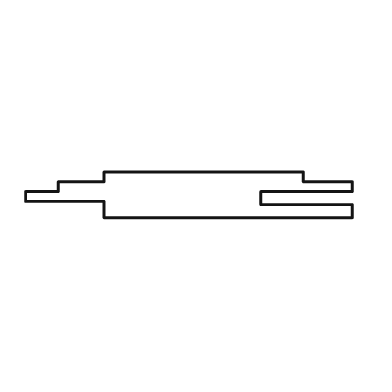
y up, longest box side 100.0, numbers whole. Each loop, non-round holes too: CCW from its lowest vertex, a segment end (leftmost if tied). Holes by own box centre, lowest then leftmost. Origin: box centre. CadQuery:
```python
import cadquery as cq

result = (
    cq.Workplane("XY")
    .moveTo(-26.0, -7.0)
    .lineTo(50.0, -7.0)
    .lineTo(50.0, -3.0)
    .lineTo(22.0, -3.0)
    .lineTo(22.0, 1.0)
    .lineTo(50.0, 1.0)
    .lineTo(50.0, 4.0)
    .lineTo(35.0, 4.0)
    .lineTo(35.0, 7.0)
    .lineTo(-26.0, 7.0)
    .lineTo(-26.0, 4.0)
    .lineTo(-40.0, 4.0)
    .lineTo(-40.0, 1.0)
    .lineTo(-50.0, 1.0)
    .lineTo(-50.0, -2.0)
    .lineTo(-26.0, -2.0)
    .close()
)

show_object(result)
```